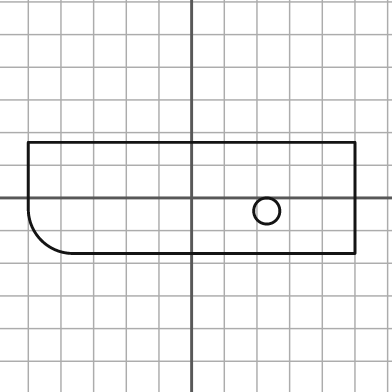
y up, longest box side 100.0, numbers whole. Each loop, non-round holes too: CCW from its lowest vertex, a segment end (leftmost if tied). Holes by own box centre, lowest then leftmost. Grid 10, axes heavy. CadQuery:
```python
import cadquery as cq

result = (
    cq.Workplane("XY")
    .moveTo(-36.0, -17.0)
    .lineTo(50.0, -17.0)
    .lineTo(50.0, 17.0)
    .lineTo(-50.0, 17.0)
    .lineTo(-50.0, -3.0)
    .threePointArc((-46.0, -13.0), (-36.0, -17.0))
    .close()
    .moveTo(23.0, -4.0)
    .circle(4.0)
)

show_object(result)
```